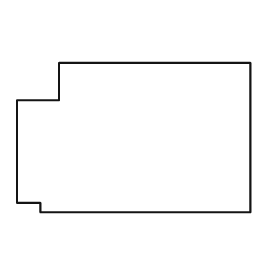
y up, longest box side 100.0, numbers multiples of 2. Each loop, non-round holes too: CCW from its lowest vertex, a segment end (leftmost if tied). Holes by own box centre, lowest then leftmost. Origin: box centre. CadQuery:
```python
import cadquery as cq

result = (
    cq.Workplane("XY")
    .moveTo(-40.0, -32.0)
    .lineTo(50.0, -32.0)
    .lineTo(50.0, 32.0)
    .lineTo(-32.0, 32.0)
    .lineTo(-32.0, 16.0)
    .lineTo(-50.0, 16.0)
    .lineTo(-50.0, -28.0)
    .lineTo(-40.0, -28.0)
    .close()
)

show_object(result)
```